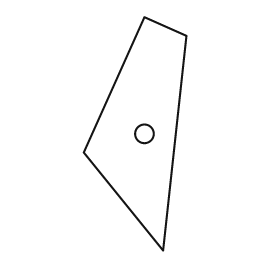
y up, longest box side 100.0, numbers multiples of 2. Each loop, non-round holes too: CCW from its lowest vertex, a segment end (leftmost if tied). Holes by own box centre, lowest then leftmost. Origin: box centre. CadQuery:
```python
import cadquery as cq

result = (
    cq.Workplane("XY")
    .moveTo(12.0, -50.0)
    .lineTo(22.0, 42.0)
    .lineTo(4.0, 50.0)
    .lineTo(-22.0, -8.0)
    .close()
    .moveTo(4.0, 0.0)
    .circle(4.0)
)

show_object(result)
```